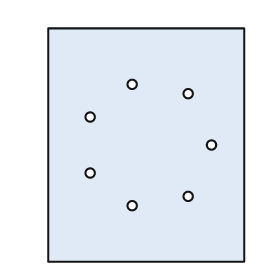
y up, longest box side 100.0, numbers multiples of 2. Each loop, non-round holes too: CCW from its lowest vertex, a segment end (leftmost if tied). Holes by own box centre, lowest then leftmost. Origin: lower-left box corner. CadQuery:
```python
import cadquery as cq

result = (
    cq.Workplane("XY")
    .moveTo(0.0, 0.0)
    .lineTo(84.0, 0.0)
    .lineTo(84.0, 100.0)
    .lineTo(0.0, 100.0)
    .close()
    .moveTo(36.0, 24.0)
    .circle(2.0)
    .moveTo(60.0, 28.0)
    .circle(2.0)
    .moveTo(18.0, 38.0)
    .circle(2.0)
    .moveTo(70.0, 50.0)
    .circle(2.0)
    .moveTo(18.0, 62.0)
    .circle(2.0)
    .moveTo(60.0, 72.0)
    .circle(2.0)
    .moveTo(36.0, 76.0)
    .circle(2.0)
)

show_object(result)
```